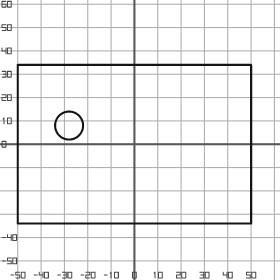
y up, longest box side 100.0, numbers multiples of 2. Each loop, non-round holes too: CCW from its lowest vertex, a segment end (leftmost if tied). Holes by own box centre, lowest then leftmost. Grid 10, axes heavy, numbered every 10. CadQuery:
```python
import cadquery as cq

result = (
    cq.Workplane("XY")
    .moveTo(-50.0, -34.0)
    .lineTo(50.0, -34.0)
    .lineTo(50.0, 34.0)
    .lineTo(-50.0, 34.0)
    .close()
    .moveTo(-28.0, 8.0)
    .circle(6.0)
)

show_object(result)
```